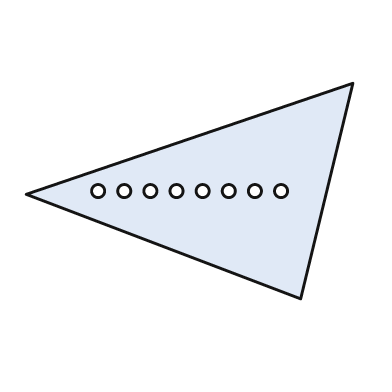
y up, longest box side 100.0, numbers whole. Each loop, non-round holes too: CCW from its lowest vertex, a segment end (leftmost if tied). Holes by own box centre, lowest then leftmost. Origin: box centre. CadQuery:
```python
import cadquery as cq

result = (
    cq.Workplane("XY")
    .moveTo(34.0, -33.0)
    .lineTo(50.0, 33.0)
    .lineTo(-50.0, -1.0)
    .close()
    .moveTo(-28.0, 0.0)
    .circle(2.0)
    .moveTo(-20.0, 0.0)
    .circle(2.0)
    .moveTo(-12.0, 0.0)
    .circle(2.0)
    .moveTo(-4.0, 0.0)
    .circle(2.0)
    .moveTo(4.0, 0.0)
    .circle(2.0)
    .moveTo(12.0, 0.0)
    .circle(2.0)
    .moveTo(20.0, 0.0)
    .circle(2.0)
    .moveTo(28.0, 0.0)
    .circle(2.0)
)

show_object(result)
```